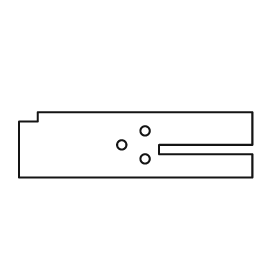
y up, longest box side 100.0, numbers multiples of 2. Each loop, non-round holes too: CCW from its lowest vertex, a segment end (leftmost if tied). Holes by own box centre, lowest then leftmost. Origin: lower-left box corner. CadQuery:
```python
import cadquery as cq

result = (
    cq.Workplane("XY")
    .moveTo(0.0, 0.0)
    .lineTo(100.0, 0.0)
    .lineTo(100.0, 10.0)
    .lineTo(60.0, 10.0)
    .lineTo(60.0, 14.0)
    .lineTo(100.0, 14.0)
    .lineTo(100.0, 28.0)
    .lineTo(8.0, 28.0)
    .lineTo(8.0, 24.0)
    .lineTo(0.0, 24.0)
    .close()
    .moveTo(54.0, 8.0)
    .circle(2.0)
    .moveTo(44.0, 14.0)
    .circle(2.0)
    .moveTo(54.0, 20.0)
    .circle(2.0)
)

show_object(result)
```